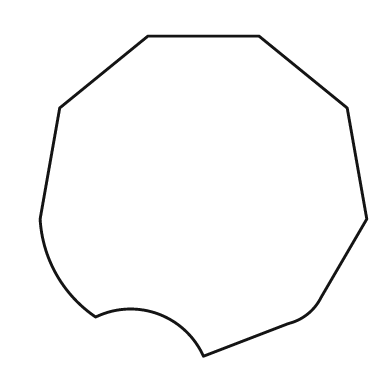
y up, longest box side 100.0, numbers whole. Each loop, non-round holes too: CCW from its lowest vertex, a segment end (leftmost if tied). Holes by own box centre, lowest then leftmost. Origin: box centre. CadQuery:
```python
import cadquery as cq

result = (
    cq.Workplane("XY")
    .moveTo(0.0, -49.0)
    .lineTo(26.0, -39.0)
    .threePointArc((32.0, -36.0), (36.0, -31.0))
    .lineTo(50.0, -7.0)
    .lineTo(44.0, 27.0)
    .lineTo(17.0, 49.0)
    .lineTo(-17.0, 49.0)
    .lineTo(-44.0, 27.0)
    .lineTo(-50.0, -7.0)
    .threePointArc((-45.0, -24.0), (-33.0, -37.0))
    .threePointArc((-14.0, -36.0), (0.0, -49.0))
    .close()
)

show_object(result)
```